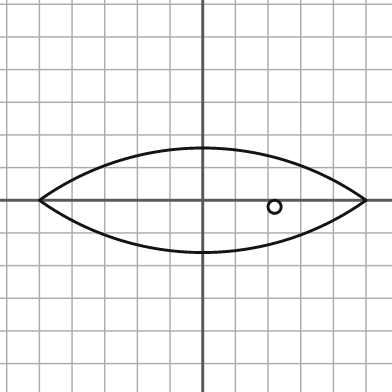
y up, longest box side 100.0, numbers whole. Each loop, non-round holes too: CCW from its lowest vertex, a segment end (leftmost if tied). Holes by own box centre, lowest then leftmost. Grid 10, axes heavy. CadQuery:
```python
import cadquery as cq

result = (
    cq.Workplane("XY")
    .moveTo(-50.0, 0.0)
    .threePointArc((0.0, -16.0), (50.0, 0.0))
    .threePointArc((0.0, 16.0), (-50.0, 0.0))
    .close()
    .moveTo(22.0, -2.0)
    .circle(2.0)
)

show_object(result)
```